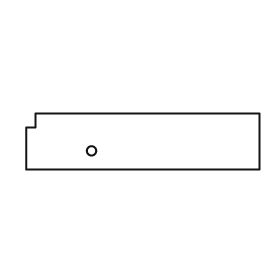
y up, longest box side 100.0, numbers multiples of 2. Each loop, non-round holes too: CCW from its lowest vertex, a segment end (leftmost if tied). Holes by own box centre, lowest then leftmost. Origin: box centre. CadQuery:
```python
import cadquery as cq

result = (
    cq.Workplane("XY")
    .moveTo(-50.0, -12.0)
    .lineTo(50.0, -12.0)
    .lineTo(50.0, 12.0)
    .lineTo(-46.0, 12.0)
    .lineTo(-46.0, 6.0)
    .lineTo(-50.0, 6.0)
    .close()
    .moveTo(-22.0, -4.0)
    .circle(2.0)
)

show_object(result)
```